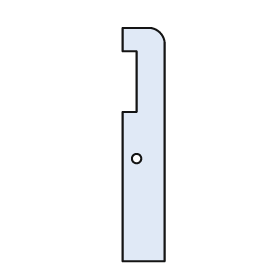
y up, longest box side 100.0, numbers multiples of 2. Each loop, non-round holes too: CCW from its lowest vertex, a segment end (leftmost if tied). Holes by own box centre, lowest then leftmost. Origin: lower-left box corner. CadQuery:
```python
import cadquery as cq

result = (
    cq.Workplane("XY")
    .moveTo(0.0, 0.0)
    .lineTo(18.0, 0.0)
    .lineTo(18.0, 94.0)
    .threePointArc((16.0, 98.0), (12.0, 100.0))
    .lineTo(0.0, 100.0)
    .lineTo(0.0, 90.0)
    .lineTo(6.0, 90.0)
    .lineTo(6.0, 64.0)
    .lineTo(0.0, 64.0)
    .close()
    .moveTo(6.0, 44.0)
    .circle(2.0)
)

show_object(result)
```